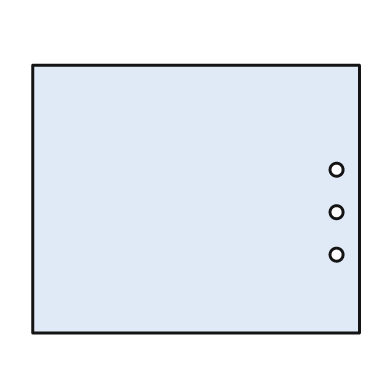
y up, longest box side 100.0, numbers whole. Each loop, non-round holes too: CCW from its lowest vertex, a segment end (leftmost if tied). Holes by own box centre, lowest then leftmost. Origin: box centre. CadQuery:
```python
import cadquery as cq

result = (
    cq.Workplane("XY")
    .moveTo(-50.0, -41.0)
    .lineTo(50.0, -41.0)
    .lineTo(50.0, 41.0)
    .lineTo(-50.0, 41.0)
    .close()
    .moveTo(43.0, -17.0)
    .circle(2.0)
    .moveTo(43.0, -4.0)
    .circle(2.0)
    .moveTo(43.0, 9.0)
    .circle(2.0)
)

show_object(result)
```